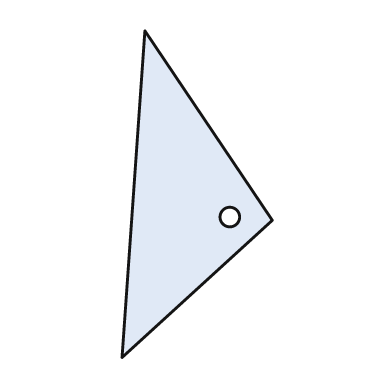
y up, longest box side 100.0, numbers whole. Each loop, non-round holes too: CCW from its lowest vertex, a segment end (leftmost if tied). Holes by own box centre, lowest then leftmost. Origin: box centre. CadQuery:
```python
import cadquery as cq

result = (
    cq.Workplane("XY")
    .moveTo(-23.0, -50.0)
    .lineTo(23.0, -8.0)
    .lineTo(-16.0, 50.0)
    .close()
    .moveTo(10.0, -7.0)
    .circle(3.0)
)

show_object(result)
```